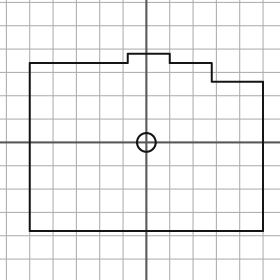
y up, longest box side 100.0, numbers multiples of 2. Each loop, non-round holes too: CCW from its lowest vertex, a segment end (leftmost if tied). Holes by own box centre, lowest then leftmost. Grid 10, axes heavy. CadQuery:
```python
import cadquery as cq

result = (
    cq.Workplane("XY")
    .moveTo(-50.0, -38.0)
    .lineTo(50.0, -38.0)
    .lineTo(50.0, 26.0)
    .lineTo(28.0, 26.0)
    .lineTo(28.0, 34.0)
    .lineTo(10.0, 34.0)
    .lineTo(10.0, 38.0)
    .lineTo(-8.0, 38.0)
    .lineTo(-8.0, 34.0)
    .lineTo(-50.0, 34.0)
    .close()
    .moveTo(0.0, 0.0)
    .circle(4.0)
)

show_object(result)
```